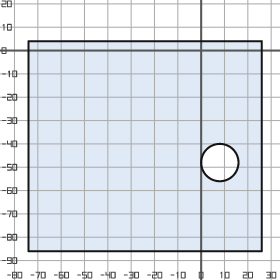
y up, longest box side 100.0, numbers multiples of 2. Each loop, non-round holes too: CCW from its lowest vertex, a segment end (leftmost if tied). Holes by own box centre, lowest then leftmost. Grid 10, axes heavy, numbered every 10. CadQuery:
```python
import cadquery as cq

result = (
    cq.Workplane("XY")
    .moveTo(-74.0, -86.0)
    .lineTo(26.0, -86.0)
    .lineTo(26.0, 4.0)
    .lineTo(-74.0, 4.0)
    .close()
    .moveTo(8.0, -48.0)
    .circle(8.0)
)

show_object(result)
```